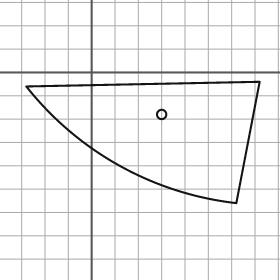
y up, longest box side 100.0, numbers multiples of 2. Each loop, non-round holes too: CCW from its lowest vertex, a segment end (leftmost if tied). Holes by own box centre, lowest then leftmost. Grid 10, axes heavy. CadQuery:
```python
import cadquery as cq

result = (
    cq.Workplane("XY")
    .moveTo(62.0, -56.0)
    .lineTo(72.0, -4.0)
    .lineTo(-28.0, -6.0)
    .threePointArc((12.0, -40.0), (62.0, -56.0))
    .close()
    .moveTo(30.0, -18.0)
    .circle(2.0)
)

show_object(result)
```